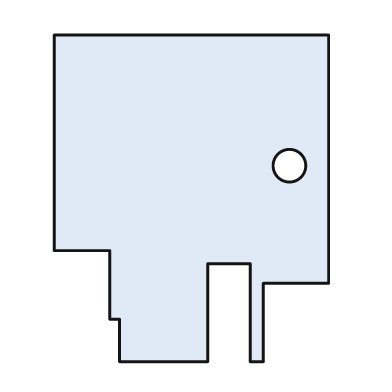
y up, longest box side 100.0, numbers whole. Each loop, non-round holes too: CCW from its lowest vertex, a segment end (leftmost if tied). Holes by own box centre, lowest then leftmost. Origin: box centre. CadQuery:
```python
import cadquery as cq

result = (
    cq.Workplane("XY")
    .moveTo(-22.0, -50.0)
    .lineTo(5.0, -50.0)
    .lineTo(5.0, -20.0)
    .lineTo(18.0, -20.0)
    .lineTo(18.0, -50.0)
    .lineTo(22.0, -50.0)
    .lineTo(22.0, -26.0)
    .lineTo(42.0, -26.0)
    .lineTo(42.0, 50.0)
    .lineTo(-42.0, 50.0)
    .lineTo(-42.0, -16.0)
    .lineTo(-25.0, -16.0)
    .lineTo(-25.0, -37.0)
    .lineTo(-22.0, -37.0)
    .close()
    .moveTo(30.0, 10.0)
    .circle(5.0)
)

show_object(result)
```